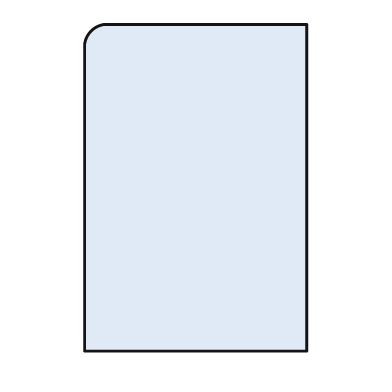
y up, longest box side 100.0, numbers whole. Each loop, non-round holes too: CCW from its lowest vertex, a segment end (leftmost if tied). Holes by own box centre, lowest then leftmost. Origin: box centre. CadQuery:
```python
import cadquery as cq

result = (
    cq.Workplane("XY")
    .moveTo(-34.0, -50.0)
    .lineTo(34.0, -50.0)
    .lineTo(34.0, 50.0)
    .lineTo(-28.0, 50.0)
    .threePointArc((-32.0, 48.0), (-34.0, 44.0))
    .close()
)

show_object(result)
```